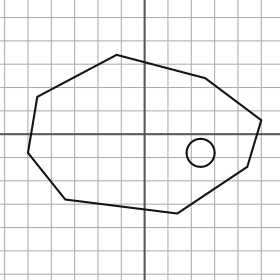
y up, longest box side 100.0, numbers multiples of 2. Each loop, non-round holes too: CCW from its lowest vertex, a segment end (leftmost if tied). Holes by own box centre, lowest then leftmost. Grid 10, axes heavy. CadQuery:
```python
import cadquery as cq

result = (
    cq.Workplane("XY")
    .moveTo(14.0, -34.0)
    .lineTo(44.0, -14.0)
    .lineTo(50.0, 6.0)
    .lineTo(26.0, 24.0)
    .lineTo(-12.0, 34.0)
    .lineTo(-46.0, 16.0)
    .lineTo(-50.0, -8.0)
    .lineTo(-34.0, -28.0)
    .close()
    .moveTo(24.0, -8.0)
    .circle(6.0)
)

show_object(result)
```